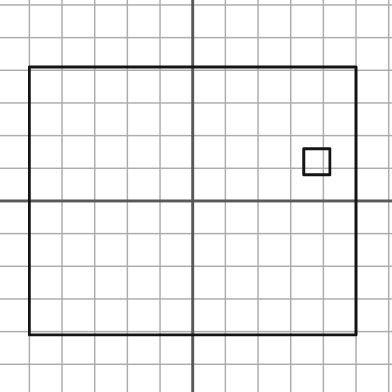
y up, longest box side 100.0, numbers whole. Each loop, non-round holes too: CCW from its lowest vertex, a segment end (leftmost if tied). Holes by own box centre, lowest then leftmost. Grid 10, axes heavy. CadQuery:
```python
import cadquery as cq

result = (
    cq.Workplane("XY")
    .moveTo(-50.0, -41.0)
    .lineTo(50.0, -41.0)
    .lineTo(50.0, 41.0)
    .lineTo(-50.0, 41.0)
    .close()
    .moveTo(34.0, 8.0)
    .lineTo(42.0, 8.0)
    .lineTo(42.0, 16.0)
    .lineTo(34.0, 16.0)
    .close()
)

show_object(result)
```